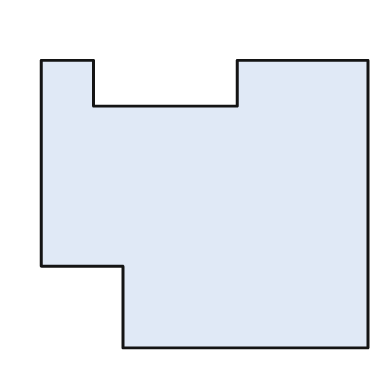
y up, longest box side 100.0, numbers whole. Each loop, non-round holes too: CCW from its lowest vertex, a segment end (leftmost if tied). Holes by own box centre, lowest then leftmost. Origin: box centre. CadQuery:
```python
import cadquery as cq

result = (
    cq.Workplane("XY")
    .moveTo(-25.0, -44.0)
    .lineTo(50.0, -44.0)
    .lineTo(50.0, 44.0)
    .lineTo(10.0, 44.0)
    .lineTo(10.0, 30.0)
    .lineTo(-34.0, 30.0)
    .lineTo(-34.0, 44.0)
    .lineTo(-50.0, 44.0)
    .lineTo(-50.0, -19.0)
    .lineTo(-25.0, -19.0)
    .close()
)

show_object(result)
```